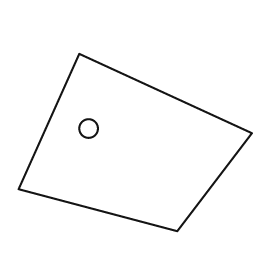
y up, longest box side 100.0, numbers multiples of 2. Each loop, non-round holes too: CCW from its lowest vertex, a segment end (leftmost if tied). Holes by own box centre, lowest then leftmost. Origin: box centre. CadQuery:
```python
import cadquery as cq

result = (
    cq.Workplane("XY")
    .moveTo(18.0, -38.0)
    .lineTo(50.0, 4.0)
    .lineTo(-24.0, 38.0)
    .lineTo(-50.0, -20.0)
    .close()
    .moveTo(-20.0, 6.0)
    .circle(4.0)
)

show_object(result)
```